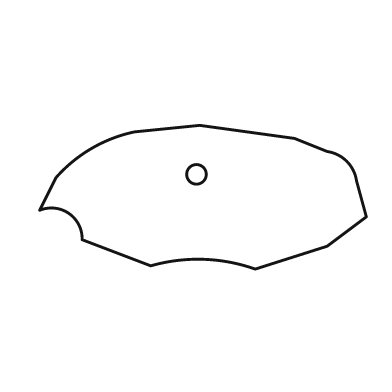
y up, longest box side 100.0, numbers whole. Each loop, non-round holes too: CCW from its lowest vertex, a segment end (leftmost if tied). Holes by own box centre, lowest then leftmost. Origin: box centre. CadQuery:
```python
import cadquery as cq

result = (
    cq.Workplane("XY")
    .moveTo(16.0, -22.0)
    .lineTo(38.0, -15.0)
    .lineTo(50.0, -6.0)
    .lineTo(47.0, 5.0)
    .threePointArc((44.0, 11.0), (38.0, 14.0))
    .lineTo(28.0, 18.0)
    .lineTo(-1.0, 22.0)
    .lineTo(-21.0, 20.0)
    .threePointArc((-34.0, 15.0), (-45.0, 6.0))
    .lineTo(-50.0, -4.0)
    .threePointArc((-41.0, -5.0), (-37.0, -13.0))
    .lineTo(-16.0, -21.0)
    .threePointArc((0.0, -19.0), (16.0, -22.0))
    .close()
    .moveTo(-2.0, 7.0)
    .circle(3.0)
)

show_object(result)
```